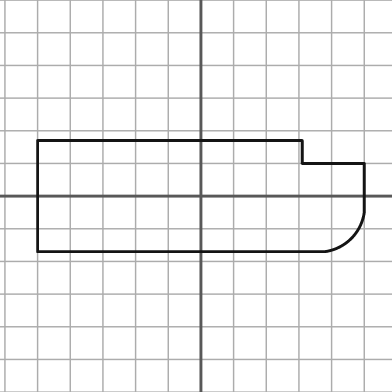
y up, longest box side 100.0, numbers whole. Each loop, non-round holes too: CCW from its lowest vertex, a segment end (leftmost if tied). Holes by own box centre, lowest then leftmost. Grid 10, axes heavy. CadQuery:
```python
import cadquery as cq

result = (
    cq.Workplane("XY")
    .moveTo(-50.0, -17.0)
    .lineTo(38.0, -17.0)
    .threePointArc((46.0, -13.0), (50.0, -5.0))
    .lineTo(50.0, 10.0)
    .lineTo(31.0, 10.0)
    .lineTo(31.0, 17.0)
    .lineTo(-50.0, 17.0)
    .close()
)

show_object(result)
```